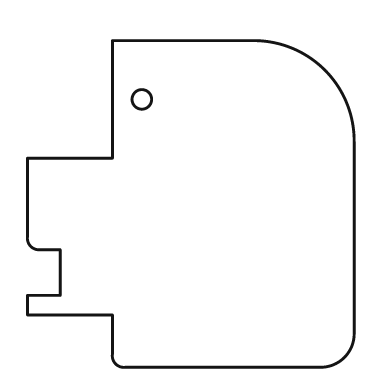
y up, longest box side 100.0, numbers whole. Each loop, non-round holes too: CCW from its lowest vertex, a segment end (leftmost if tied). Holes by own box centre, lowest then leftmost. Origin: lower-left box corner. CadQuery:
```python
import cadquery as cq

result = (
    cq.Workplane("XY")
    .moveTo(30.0, 0.0)
    .lineTo(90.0, 0.0)
    .threePointArc((97.0, 3.0), (100.0, 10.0))
    .lineTo(100.0, 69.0)
    .threePointArc((91.0, 91.0), (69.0, 100.0))
    .lineTo(26.0, 100.0)
    .lineTo(26.0, 64.0)
    .lineTo(0.0, 64.0)
    .lineTo(0.0, 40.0)
    .threePointArc((1.0, 37.0), (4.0, 36.0))
    .lineTo(10.0, 36.0)
    .lineTo(10.0, 22.0)
    .lineTo(0.0, 22.0)
    .lineTo(0.0, 16.0)
    .lineTo(26.0, 16.0)
    .lineTo(26.0, 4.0)
    .threePointArc((27.0, 1.0), (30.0, 0.0))
    .close()
    .moveTo(35.0, 82.0)
    .circle(3.0)
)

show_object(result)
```